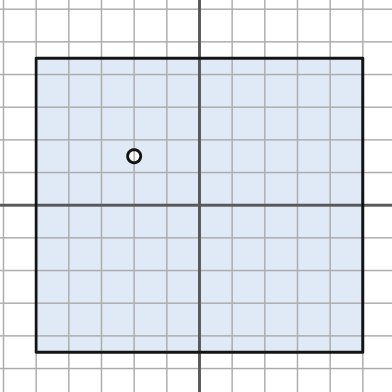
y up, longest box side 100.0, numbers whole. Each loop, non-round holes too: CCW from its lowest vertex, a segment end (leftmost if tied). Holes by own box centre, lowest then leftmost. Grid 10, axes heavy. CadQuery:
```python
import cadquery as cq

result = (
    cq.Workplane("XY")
    .moveTo(-50.0, -45.0)
    .lineTo(50.0, -45.0)
    .lineTo(50.0, 45.0)
    .lineTo(-50.0, 45.0)
    .close()
    .moveTo(-20.0, 15.0)
    .circle(2.0)
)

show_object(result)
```